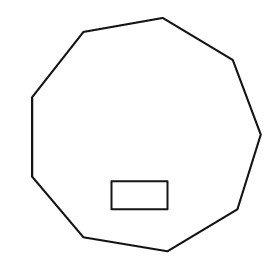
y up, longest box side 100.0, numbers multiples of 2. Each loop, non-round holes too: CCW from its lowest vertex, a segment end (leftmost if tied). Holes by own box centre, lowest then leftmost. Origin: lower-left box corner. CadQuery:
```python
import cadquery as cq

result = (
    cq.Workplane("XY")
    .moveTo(58.0, 0.0)
    .lineTo(88.0, 18.0)
    .lineTo(98.0, 50.0)
    .lineTo(86.0, 82.0)
    .lineTo(56.0, 100.0)
    .lineTo(22.0, 94.0)
    .lineTo(0.0, 66.0)
    .lineTo(0.0, 32.0)
    .lineTo(22.0, 6.0)
    .close()
    .moveTo(34.0, 18.0)
    .lineTo(58.0, 18.0)
    .lineTo(58.0, 30.0)
    .lineTo(34.0, 30.0)
    .close()
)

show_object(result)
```